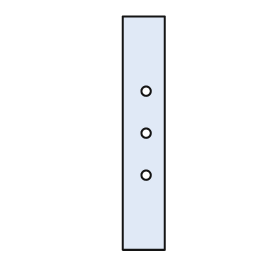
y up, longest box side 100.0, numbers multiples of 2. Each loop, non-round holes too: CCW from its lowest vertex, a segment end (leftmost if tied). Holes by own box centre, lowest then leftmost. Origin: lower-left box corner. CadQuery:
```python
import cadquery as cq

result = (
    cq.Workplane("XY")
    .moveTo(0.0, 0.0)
    .lineTo(18.0, 0.0)
    .lineTo(18.0, 100.0)
    .lineTo(0.0, 100.0)
    .close()
    .moveTo(10.0, 32.0)
    .circle(2.0)
    .moveTo(10.0, 50.0)
    .circle(2.0)
    .moveTo(10.0, 68.0)
    .circle(2.0)
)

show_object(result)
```